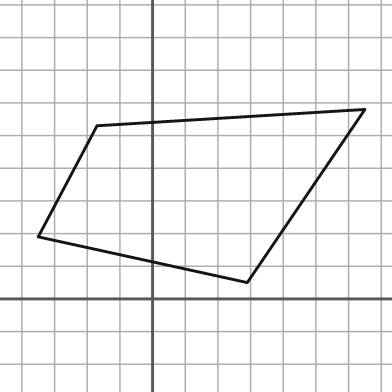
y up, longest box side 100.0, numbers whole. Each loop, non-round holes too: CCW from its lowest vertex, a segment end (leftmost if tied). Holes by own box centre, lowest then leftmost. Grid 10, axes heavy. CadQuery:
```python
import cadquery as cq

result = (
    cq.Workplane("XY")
    .moveTo(29.0, 5.0)
    .lineTo(65.0, 58.0)
    .lineTo(-17.0, 53.0)
    .lineTo(-35.0, 19.0)
    .close()
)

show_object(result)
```